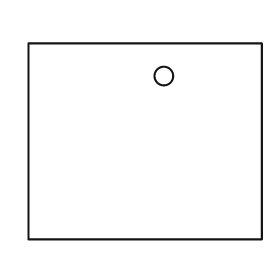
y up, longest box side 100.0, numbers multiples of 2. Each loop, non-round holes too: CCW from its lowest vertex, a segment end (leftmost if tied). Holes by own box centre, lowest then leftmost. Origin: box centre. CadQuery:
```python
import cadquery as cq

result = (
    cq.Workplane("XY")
    .moveTo(-50.0, -42.0)
    .lineTo(50.0, -42.0)
    .lineTo(50.0, 42.0)
    .lineTo(-50.0, 42.0)
    .close()
    .moveTo(8.0, 28.0)
    .circle(4.0)
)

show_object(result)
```